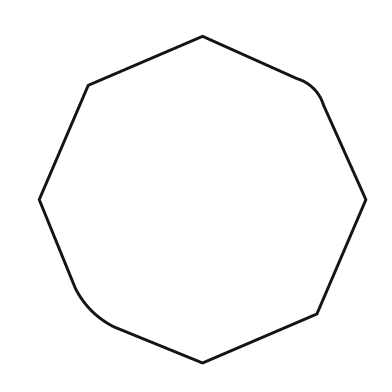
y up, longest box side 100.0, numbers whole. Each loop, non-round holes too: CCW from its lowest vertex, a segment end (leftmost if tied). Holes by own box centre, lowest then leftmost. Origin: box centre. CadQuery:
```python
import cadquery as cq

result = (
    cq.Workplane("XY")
    .moveTo(0.0, -50.0)
    .lineTo(35.0, -35.0)
    .lineTo(50.0, 0.0)
    .lineTo(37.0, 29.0)
    .threePointArc((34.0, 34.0), (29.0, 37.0))
    .lineTo(0.0, 50.0)
    .lineTo(-35.0, 35.0)
    .lineTo(-50.0, 0.0)
    .lineTo(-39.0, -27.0)
    .threePointArc((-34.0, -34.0), (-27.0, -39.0))
    .close()
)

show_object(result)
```